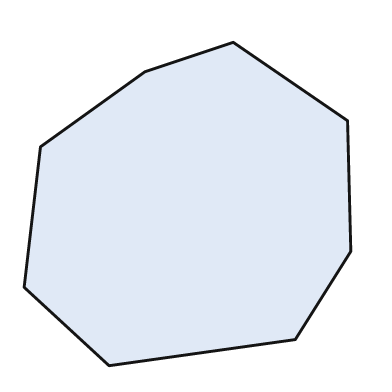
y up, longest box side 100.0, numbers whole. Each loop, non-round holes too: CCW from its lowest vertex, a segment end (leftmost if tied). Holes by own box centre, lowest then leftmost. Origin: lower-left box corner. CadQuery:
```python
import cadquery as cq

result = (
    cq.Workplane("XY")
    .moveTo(26.0, 0.0)
    .lineTo(83.0, 8.0)
    .lineTo(100.0, 35.0)
    .lineTo(99.0, 75.0)
    .lineTo(64.0, 99.0)
    .lineTo(37.0, 90.0)
    .lineTo(5.0, 67.0)
    .lineTo(0.0, 24.0)
    .close()
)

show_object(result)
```